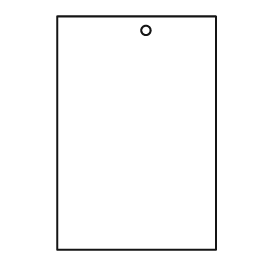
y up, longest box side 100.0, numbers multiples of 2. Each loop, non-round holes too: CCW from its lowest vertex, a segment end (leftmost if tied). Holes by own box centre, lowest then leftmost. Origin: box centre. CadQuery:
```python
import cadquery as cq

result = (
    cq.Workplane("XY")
    .moveTo(-34.0, -50.0)
    .lineTo(34.0, -50.0)
    .lineTo(34.0, 50.0)
    .lineTo(-34.0, 50.0)
    .close()
    .moveTo(4.0, 44.0)
    .circle(2.0)
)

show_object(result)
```